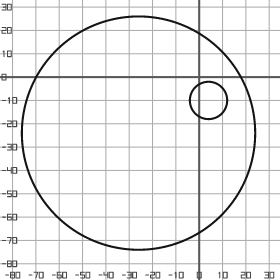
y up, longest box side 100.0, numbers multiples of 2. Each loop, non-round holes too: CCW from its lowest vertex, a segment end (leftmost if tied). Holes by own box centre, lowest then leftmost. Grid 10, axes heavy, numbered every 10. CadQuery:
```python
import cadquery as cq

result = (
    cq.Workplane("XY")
    .moveTo(-26.0, -24.0)
    .circle(50.0)
    .moveTo(4.0, -10.0)
    .circle(8.0)
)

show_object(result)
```